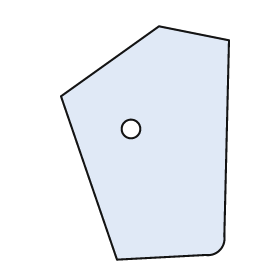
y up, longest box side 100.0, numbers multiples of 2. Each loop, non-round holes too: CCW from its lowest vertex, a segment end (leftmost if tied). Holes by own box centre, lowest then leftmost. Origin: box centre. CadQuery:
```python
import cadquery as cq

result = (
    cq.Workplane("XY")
    .moveTo(-12.0, -50.0)
    .lineTo(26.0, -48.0)
    .threePointArc((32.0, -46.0), (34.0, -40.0))
    .lineTo(36.0, 44.0)
    .lineTo(6.0, 50.0)
    .lineTo(-36.0, 20.0)
    .close()
    .moveTo(-6.0, 6.0)
    .circle(4.0)
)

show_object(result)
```